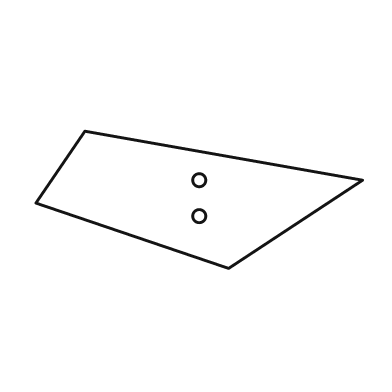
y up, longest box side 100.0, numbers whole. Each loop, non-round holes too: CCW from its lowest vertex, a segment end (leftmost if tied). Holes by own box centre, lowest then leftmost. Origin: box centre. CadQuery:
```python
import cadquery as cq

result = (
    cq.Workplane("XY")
    .moveTo(9.0, -21.0)
    .lineTo(50.0, 6.0)
    .lineTo(-35.0, 21.0)
    .lineTo(-50.0, -1.0)
    .close()
    .moveTo(0.0, -5.0)
    .circle(2.0)
    .moveTo(0.0, 6.0)
    .circle(2.0)
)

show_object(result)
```